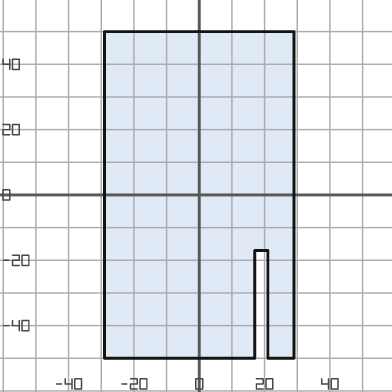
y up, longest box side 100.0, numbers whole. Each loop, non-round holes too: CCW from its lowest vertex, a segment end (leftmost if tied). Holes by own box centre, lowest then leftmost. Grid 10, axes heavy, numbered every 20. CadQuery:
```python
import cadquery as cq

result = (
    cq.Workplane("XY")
    .moveTo(-29.0, -50.0)
    .lineTo(17.0, -50.0)
    .lineTo(17.0, -17.0)
    .lineTo(21.0, -17.0)
    .lineTo(21.0, -50.0)
    .lineTo(29.0, -50.0)
    .lineTo(29.0, 50.0)
    .lineTo(-29.0, 50.0)
    .close()
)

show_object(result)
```